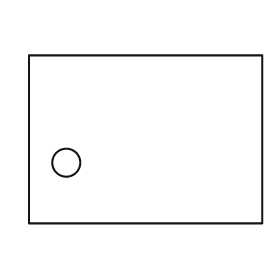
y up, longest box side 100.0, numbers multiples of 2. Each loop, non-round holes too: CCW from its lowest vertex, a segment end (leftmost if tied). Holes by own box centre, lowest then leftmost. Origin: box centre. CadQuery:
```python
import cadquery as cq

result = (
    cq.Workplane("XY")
    .moveTo(-50.0, -36.0)
    .lineTo(50.0, -36.0)
    .lineTo(50.0, 36.0)
    .lineTo(-50.0, 36.0)
    .close()
    .moveTo(-34.0, -10.0)
    .circle(6.0)
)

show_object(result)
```